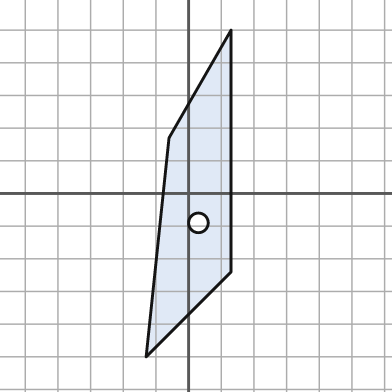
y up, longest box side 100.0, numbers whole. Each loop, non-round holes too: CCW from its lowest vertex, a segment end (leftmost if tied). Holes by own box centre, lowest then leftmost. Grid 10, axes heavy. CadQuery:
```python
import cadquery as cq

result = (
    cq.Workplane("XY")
    .moveTo(-13.0, -50.0)
    .lineTo(13.0, -24.0)
    .lineTo(13.0, 50.0)
    .lineTo(-6.0, 17.0)
    .close()
    .moveTo(3.0, -9.0)
    .circle(3.0)
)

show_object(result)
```